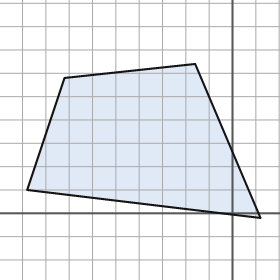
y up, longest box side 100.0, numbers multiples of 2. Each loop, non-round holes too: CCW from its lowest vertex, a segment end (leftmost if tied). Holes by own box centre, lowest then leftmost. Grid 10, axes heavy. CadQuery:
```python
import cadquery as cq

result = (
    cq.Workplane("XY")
    .moveTo(12.0, -2.0)
    .lineTo(-16.0, 64.0)
    .lineTo(-72.0, 58.0)
    .lineTo(-88.0, 10.0)
    .close()
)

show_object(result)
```